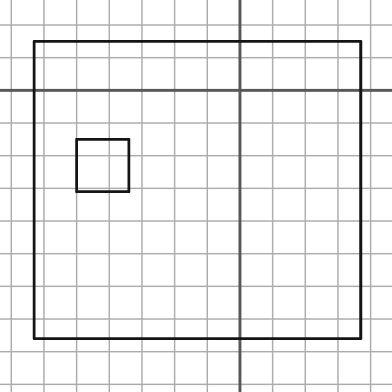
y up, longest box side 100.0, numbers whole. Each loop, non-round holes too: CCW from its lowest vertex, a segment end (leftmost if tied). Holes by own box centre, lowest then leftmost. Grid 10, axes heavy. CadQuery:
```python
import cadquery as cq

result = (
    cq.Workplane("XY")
    .moveTo(-63.0, -76.0)
    .lineTo(37.0, -76.0)
    .lineTo(37.0, 15.0)
    .lineTo(-63.0, 15.0)
    .close()
    .moveTo(-50.0, -31.0)
    .lineTo(-34.0, -31.0)
    .lineTo(-34.0, -15.0)
    .lineTo(-50.0, -15.0)
    .close()
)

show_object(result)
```